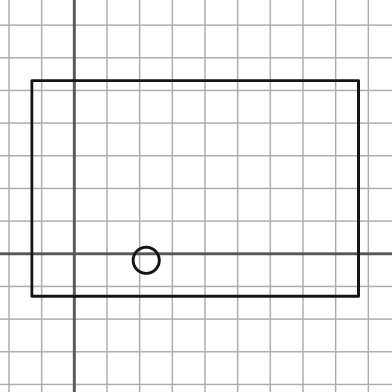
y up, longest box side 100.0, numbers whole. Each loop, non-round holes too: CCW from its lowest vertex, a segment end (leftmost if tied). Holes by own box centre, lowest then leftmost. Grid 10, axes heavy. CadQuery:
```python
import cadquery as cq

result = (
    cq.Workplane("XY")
    .moveTo(-13.0, -13.0)
    .lineTo(87.0, -13.0)
    .lineTo(87.0, 53.0)
    .lineTo(-13.0, 53.0)
    .close()
    .moveTo(22.0, -2.0)
    .circle(4.0)
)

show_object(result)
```